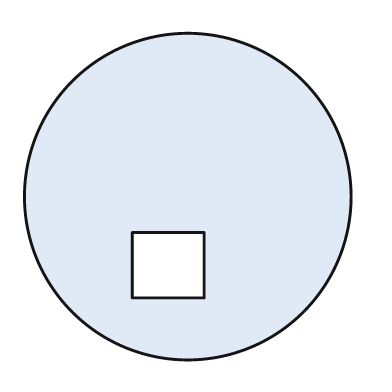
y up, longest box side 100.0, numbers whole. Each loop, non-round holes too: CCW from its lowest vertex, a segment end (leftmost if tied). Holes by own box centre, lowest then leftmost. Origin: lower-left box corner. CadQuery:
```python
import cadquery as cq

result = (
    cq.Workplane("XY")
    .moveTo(50.0, 50.0)
    .circle(50.0)
    .moveTo(33.0, 19.0)
    .lineTo(55.0, 19.0)
    .lineTo(55.0, 39.0)
    .lineTo(33.0, 39.0)
    .close()
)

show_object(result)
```